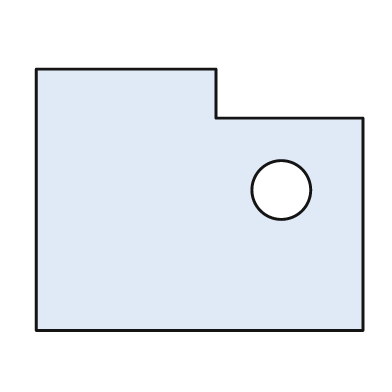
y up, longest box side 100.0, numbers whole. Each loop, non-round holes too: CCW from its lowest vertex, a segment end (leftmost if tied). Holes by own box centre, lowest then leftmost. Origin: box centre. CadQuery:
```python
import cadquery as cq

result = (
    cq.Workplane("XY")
    .moveTo(-50.0, -40.0)
    .lineTo(50.0, -40.0)
    .lineTo(50.0, 25.0)
    .lineTo(5.0, 25.0)
    .lineTo(5.0, 40.0)
    .lineTo(-50.0, 40.0)
    .close()
    .moveTo(25.0, 3.0)
    .circle(9.0)
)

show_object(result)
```